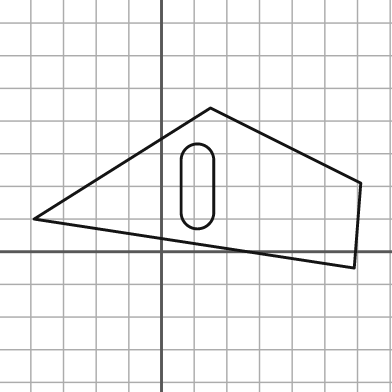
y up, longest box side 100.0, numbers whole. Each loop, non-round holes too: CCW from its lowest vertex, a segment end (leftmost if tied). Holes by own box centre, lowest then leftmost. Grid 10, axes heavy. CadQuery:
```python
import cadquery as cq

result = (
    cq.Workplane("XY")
    .moveTo(59.0, -5.0)
    .lineTo(61.0, 21.0)
    .lineTo(15.0, 44.0)
    .lineTo(-39.0, 10.0)
    .close()
    .moveTo(6.0, 12.0)
    .threePointArc((11.0, 7.0), (16.0, 12.0))
    .lineTo(16.0, 28.0)
    .threePointArc((11.0, 33.0), (6.0, 28.0))
    .close()
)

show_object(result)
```